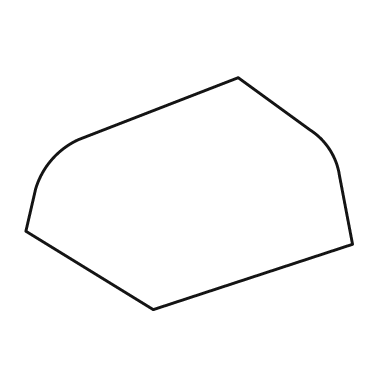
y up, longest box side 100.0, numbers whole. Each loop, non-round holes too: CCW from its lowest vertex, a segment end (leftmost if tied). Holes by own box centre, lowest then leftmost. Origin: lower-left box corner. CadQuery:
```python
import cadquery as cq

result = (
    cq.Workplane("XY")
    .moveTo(39.0, 0.0)
    .lineTo(100.0, 20.0)
    .lineTo(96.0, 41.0)
    .threePointArc((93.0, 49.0), (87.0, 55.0))
    .lineTo(65.0, 71.0)
    .lineTo(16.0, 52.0)
    .threePointArc((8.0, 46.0), (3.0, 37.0))
    .lineTo(0.0, 24.0)
    .close()
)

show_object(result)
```